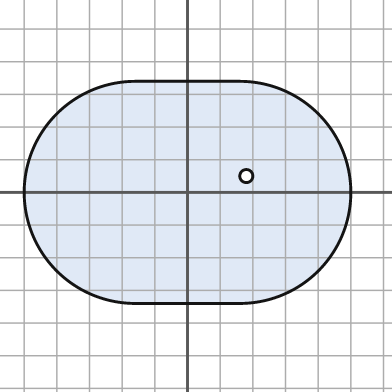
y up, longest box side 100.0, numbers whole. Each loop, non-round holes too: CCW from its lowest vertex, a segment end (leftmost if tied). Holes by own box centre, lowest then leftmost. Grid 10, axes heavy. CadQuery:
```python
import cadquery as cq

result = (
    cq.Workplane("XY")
    .moveTo(-16.0, -34.0)
    .lineTo(16.0, -34.0)
    .threePointArc((50.0, 0.0), (16.0, 34.0))
    .lineTo(-16.0, 34.0)
    .threePointArc((-50.0, 0.0), (-16.0, -34.0))
    .close()
    .moveTo(18.0, 5.0)
    .circle(2.0)
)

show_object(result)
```